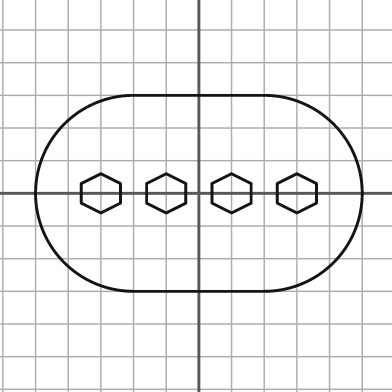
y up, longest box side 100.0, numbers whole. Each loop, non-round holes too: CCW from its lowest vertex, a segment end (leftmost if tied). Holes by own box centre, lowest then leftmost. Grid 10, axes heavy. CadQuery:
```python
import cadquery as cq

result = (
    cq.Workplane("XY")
    .moveTo(-20.0, -30.0)
    .lineTo(20.0, -30.0)
    .threePointArc((50.0, 0.0), (20.0, 30.0))
    .lineTo(-20.0, 30.0)
    .threePointArc((-50.0, 0.0), (-20.0, -30.0))
    .close()
    .moveTo(-30.0, -6.0)
    .lineTo(-24.0, -3.0)
    .lineTo(-24.0, 3.0)
    .lineTo(-30.0, 6.0)
    .lineTo(-36.0, 3.0)
    .lineTo(-36.0, -3.0)
    .close()
    .moveTo(-10.0, -6.0)
    .lineTo(-4.0, -3.0)
    .lineTo(-4.0, 3.0)
    .lineTo(-10.0, 6.0)
    .lineTo(-16.0, 3.0)
    .lineTo(-16.0, -3.0)
    .close()
    .moveTo(10.0, -6.0)
    .lineTo(16.0, -3.0)
    .lineTo(16.0, 3.0)
    .lineTo(10.0, 6.0)
    .lineTo(4.0, 3.0)
    .lineTo(4.0, -3.0)
    .close()
    .moveTo(30.0, -6.0)
    .lineTo(36.0, -3.0)
    .lineTo(36.0, 3.0)
    .lineTo(30.0, 6.0)
    .lineTo(24.0, 3.0)
    .lineTo(24.0, -3.0)
    .close()
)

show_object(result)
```